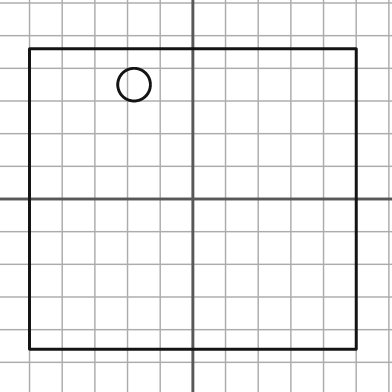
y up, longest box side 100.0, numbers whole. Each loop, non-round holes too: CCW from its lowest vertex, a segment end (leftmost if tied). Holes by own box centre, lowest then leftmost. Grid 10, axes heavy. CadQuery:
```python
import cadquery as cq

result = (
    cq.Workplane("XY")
    .moveTo(-50.0, -46.0)
    .lineTo(50.0, -46.0)
    .lineTo(50.0, 46.0)
    .lineTo(-50.0, 46.0)
    .close()
    .moveTo(-18.0, 35.0)
    .circle(5.0)
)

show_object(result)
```